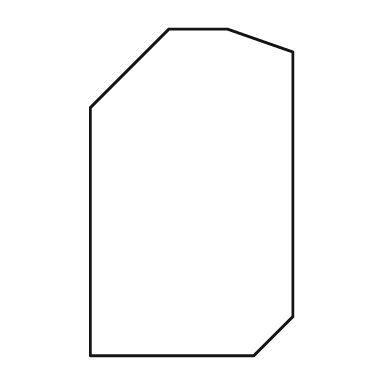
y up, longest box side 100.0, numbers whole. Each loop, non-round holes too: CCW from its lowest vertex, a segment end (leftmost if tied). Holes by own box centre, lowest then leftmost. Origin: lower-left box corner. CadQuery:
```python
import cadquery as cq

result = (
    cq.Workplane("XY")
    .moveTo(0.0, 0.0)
    .lineTo(50.0, 0.0)
    .lineTo(62.0, 12.0)
    .lineTo(62.0, 93.0)
    .lineTo(42.0, 100.0)
    .lineTo(24.0, 100.0)
    .lineTo(0.0, 76.0)
    .close()
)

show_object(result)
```